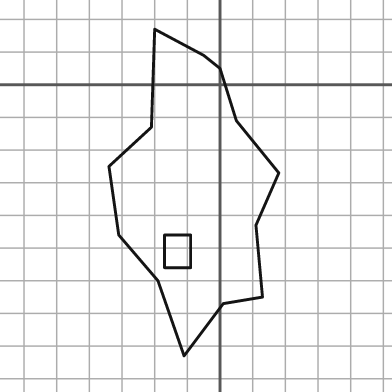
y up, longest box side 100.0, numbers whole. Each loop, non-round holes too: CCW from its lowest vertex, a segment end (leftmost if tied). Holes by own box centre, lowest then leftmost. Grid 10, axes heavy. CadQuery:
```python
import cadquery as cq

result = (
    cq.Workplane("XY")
    .moveTo(-11.0, -83.0)
    .lineTo(1.0, -67.0)
    .lineTo(13.0, -65.0)
    .lineTo(11.0, -43.0)
    .lineTo(18.0, -27.0)
    .lineTo(5.0, -11.0)
    .lineTo(0.0, 5.0)
    .lineTo(-5.0, 9.0)
    .lineTo(-20.0, 17.0)
    .lineTo(-21.0, -13.0)
    .lineTo(-34.0, -25.0)
    .lineTo(-31.0, -46.0)
    .lineTo(-19.0, -60.0)
    .close()
    .moveTo(-17.0, -56.0)
    .lineTo(-9.0, -56.0)
    .lineTo(-9.0, -46.0)
    .lineTo(-17.0, -46.0)
    .close()
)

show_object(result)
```